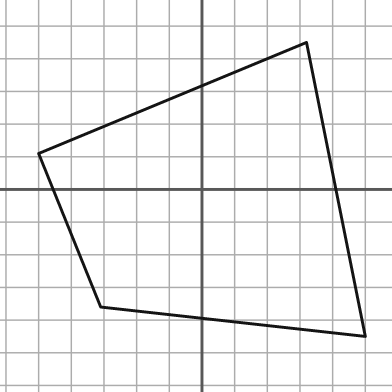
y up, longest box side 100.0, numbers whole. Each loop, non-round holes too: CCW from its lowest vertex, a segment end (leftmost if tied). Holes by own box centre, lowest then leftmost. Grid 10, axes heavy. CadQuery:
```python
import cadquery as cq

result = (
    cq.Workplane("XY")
    .moveTo(50.0, -45.0)
    .lineTo(32.0, 45.0)
    .lineTo(-50.0, 11.0)
    .lineTo(-31.0, -36.0)
    .close()
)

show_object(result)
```